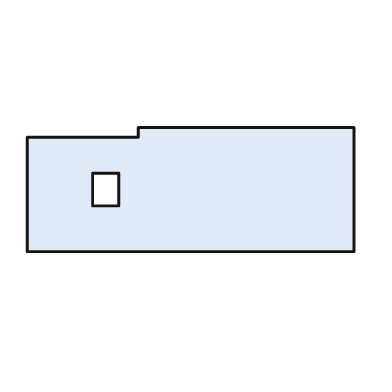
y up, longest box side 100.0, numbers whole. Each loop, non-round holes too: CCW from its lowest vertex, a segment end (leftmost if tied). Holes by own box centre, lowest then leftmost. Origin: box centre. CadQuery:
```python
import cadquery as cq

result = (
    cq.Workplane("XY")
    .moveTo(-50.0, -19.0)
    .lineTo(50.0, -19.0)
    .lineTo(50.0, 19.0)
    .lineTo(-16.0, 19.0)
    .lineTo(-16.0, 16.0)
    .lineTo(-50.0, 16.0)
    .close()
    .moveTo(-30.0, -5.0)
    .lineTo(-22.0, -5.0)
    .lineTo(-22.0, 5.0)
    .lineTo(-30.0, 5.0)
    .close()
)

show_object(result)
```